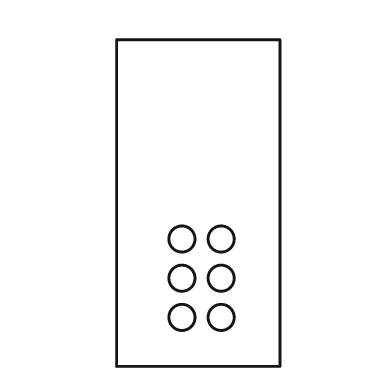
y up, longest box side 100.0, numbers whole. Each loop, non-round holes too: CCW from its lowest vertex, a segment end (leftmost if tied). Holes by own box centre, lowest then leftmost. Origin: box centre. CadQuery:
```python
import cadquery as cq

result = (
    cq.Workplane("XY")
    .moveTo(-25.0, -50.0)
    .lineTo(25.0, -50.0)
    .lineTo(25.0, 50.0)
    .lineTo(-25.0, 50.0)
    .close()
    .moveTo(-5.0, -35.0)
    .circle(4.0)
    .moveTo(7.0, -35.0)
    .circle(4.0)
    .moveTo(-5.0, -23.0)
    .circle(4.0)
    .moveTo(7.0, -23.0)
    .circle(4.0)
    .moveTo(-5.0, -11.0)
    .circle(4.0)
    .moveTo(7.0, -11.0)
    .circle(4.0)
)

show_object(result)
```